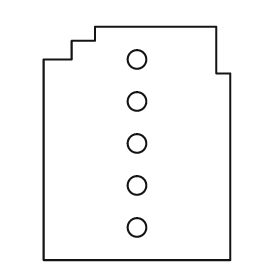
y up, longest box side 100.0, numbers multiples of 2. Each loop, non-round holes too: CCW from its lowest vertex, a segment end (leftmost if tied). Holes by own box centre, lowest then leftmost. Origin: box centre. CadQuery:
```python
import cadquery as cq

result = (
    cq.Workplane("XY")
    .moveTo(-40.0, -50.0)
    .lineTo(40.0, -50.0)
    .lineTo(40.0, 30.0)
    .lineTo(34.0, 30.0)
    .lineTo(34.0, 50.0)
    .lineTo(-18.0, 50.0)
    .lineTo(-18.0, 44.0)
    .lineTo(-28.0, 44.0)
    .lineTo(-28.0, 36.0)
    .lineTo(-40.0, 36.0)
    .close()
    .moveTo(0.0, -36.0)
    .circle(4.0)
    .moveTo(0.0, -18.0)
    .circle(4.0)
    .moveTo(0.0, 0.0)
    .circle(4.0)
    .moveTo(0.0, 18.0)
    .circle(4.0)
    .moveTo(0.0, 36.0)
    .circle(4.0)
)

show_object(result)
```